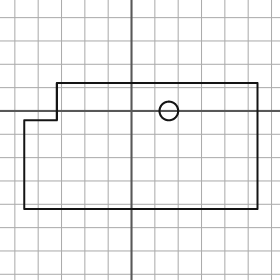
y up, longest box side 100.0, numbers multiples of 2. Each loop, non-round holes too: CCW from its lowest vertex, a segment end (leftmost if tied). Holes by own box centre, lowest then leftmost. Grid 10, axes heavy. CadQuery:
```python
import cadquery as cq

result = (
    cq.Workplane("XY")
    .moveTo(-46.0, -42.0)
    .lineTo(54.0, -42.0)
    .lineTo(54.0, 12.0)
    .lineTo(-32.0, 12.0)
    .lineTo(-32.0, -4.0)
    .lineTo(-46.0, -4.0)
    .close()
    .moveTo(16.0, 0.0)
    .circle(4.0)
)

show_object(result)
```